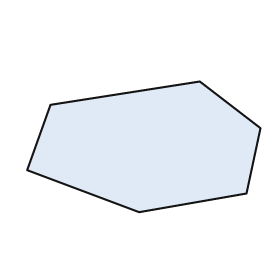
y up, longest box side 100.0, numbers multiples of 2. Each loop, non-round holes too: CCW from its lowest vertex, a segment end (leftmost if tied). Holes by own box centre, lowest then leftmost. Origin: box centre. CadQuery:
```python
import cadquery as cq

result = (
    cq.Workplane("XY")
    .moveTo(-2.0, -28.0)
    .lineTo(44.0, -20.0)
    .lineTo(50.0, 8.0)
    .lineTo(24.0, 28.0)
    .lineTo(-40.0, 18.0)
    .lineTo(-50.0, -10.0)
    .close()
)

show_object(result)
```